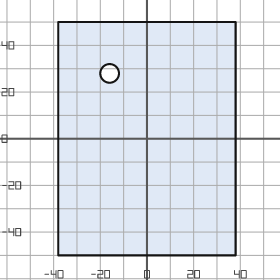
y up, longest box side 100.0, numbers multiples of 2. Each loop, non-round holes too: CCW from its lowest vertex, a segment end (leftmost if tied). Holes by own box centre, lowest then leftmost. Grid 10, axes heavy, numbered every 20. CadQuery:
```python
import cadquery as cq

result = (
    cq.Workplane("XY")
    .moveTo(-38.0, -50.0)
    .lineTo(38.0, -50.0)
    .lineTo(38.0, 50.0)
    .lineTo(-38.0, 50.0)
    .close()
    .moveTo(-16.0, 28.0)
    .circle(4.0)
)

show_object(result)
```